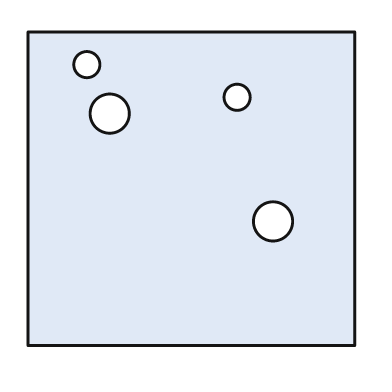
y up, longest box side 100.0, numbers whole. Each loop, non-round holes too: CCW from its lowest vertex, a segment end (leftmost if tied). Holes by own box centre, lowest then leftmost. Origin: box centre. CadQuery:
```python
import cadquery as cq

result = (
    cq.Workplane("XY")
    .moveTo(-50.0, -48.0)
    .lineTo(50.0, -48.0)
    .lineTo(50.0, 48.0)
    .lineTo(-50.0, 48.0)
    .close()
    .moveTo(25.0, -10.0)
    .circle(6.0)
    .moveTo(-25.0, 23.0)
    .circle(6.0)
    .moveTo(14.0, 28.0)
    .circle(4.0)
    .moveTo(-32.0, 38.0)
    .circle(4.0)
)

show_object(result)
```